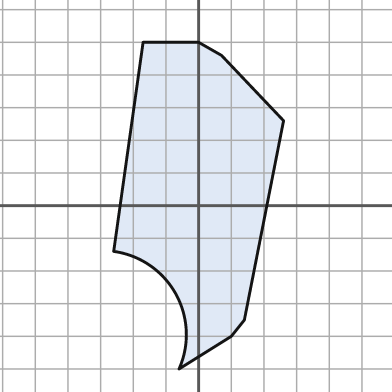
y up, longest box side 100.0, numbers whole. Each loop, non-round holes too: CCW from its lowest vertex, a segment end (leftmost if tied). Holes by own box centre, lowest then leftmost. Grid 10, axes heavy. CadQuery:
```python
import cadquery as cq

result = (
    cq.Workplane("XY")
    .moveTo(-6.0, -50.0)
    .lineTo(10.0, -40.0)
    .lineTo(14.0, -35.0)
    .lineTo(26.0, 26.0)
    .lineTo(7.0, 46.0)
    .lineTo(0.0, 50.0)
    .lineTo(-17.0, 50.0)
    .lineTo(-26.0, -14.0)
    .threePointArc((-7.0, -27.0), (-6.0, -50.0))
    .close()
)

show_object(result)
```